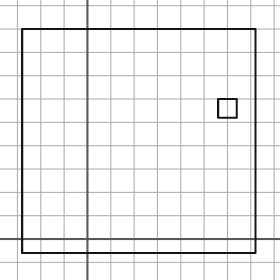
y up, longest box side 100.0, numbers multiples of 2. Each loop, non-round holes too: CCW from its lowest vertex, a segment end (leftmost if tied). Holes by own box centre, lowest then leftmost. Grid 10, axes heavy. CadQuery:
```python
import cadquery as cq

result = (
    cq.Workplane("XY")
    .moveTo(-28.0, -6.0)
    .lineTo(72.0, -6.0)
    .lineTo(72.0, 90.0)
    .lineTo(-28.0, 90.0)
    .close()
    .moveTo(56.0, 52.0)
    .lineTo(64.0, 52.0)
    .lineTo(64.0, 60.0)
    .lineTo(56.0, 60.0)
    .close()
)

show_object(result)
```